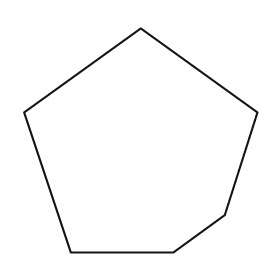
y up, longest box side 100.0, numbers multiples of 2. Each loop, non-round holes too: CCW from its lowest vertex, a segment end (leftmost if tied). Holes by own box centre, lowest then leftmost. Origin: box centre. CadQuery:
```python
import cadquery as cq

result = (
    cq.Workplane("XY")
    .moveTo(-30.0, -48.0)
    .lineTo(14.0, -48.0)
    .lineTo(36.0, -32.0)
    .lineTo(50.0, 12.0)
    .lineTo(0.0, 48.0)
    .lineTo(-50.0, 12.0)
    .close()
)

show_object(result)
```